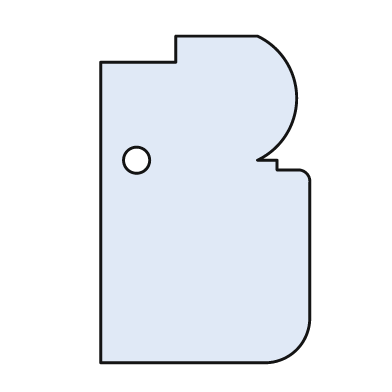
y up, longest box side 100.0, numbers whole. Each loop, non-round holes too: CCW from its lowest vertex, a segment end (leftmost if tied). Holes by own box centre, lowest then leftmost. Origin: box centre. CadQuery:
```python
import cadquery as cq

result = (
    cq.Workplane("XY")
    .moveTo(-32.0, -50.0)
    .lineTo(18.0, -50.0)
    .threePointArc((28.0, -46.0), (32.0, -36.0))
    .lineTo(32.0, 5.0)
    .threePointArc((31.0, 8.0), (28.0, 9.0))
    .lineTo(22.0, 9.0)
    .lineTo(22.0, 12.0)
    .lineTo(16.0, 12.0)
    .threePointArc((28.0, 31.0), (16.0, 50.0))
    .lineTo(-9.0, 50.0)
    .lineTo(-9.0, 42.0)
    .lineTo(-32.0, 42.0)
    .close()
    .moveTo(-21.0, 12.0)
    .circle(4.0)
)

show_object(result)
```